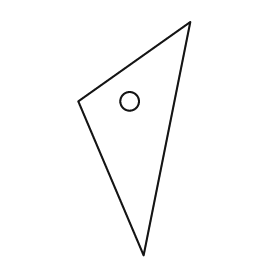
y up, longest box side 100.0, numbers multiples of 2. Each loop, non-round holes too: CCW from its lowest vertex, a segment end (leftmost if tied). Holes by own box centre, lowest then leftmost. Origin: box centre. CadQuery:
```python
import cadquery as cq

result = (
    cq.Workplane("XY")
    .moveTo(4.0, -50.0)
    .lineTo(24.0, 50.0)
    .lineTo(-24.0, 16.0)
    .close()
    .moveTo(-2.0, 16.0)
    .circle(4.0)
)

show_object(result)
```